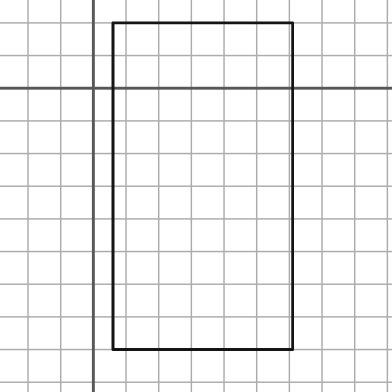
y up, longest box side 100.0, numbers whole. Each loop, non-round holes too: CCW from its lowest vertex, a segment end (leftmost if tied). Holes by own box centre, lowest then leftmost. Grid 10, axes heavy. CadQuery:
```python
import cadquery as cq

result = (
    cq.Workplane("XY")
    .moveTo(6.0, -80.0)
    .lineTo(61.0, -80.0)
    .lineTo(61.0, 20.0)
    .lineTo(6.0, 20.0)
    .close()
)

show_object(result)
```